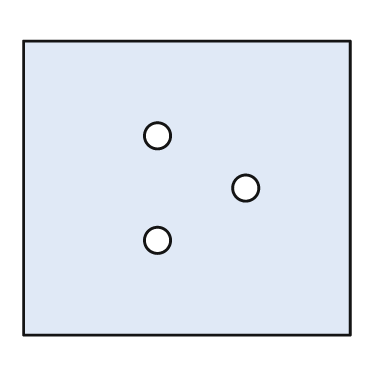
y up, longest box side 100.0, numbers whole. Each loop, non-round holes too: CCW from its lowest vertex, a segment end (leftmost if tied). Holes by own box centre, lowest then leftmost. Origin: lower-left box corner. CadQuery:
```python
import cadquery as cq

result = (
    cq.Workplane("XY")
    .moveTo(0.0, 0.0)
    .lineTo(100.0, 0.0)
    .lineTo(100.0, 90.0)
    .lineTo(0.0, 90.0)
    .close()
    .moveTo(41.0, 29.0)
    .circle(4.0)
    .moveTo(68.0, 45.0)
    .circle(4.0)
    .moveTo(41.0, 61.0)
    .circle(4.0)
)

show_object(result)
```